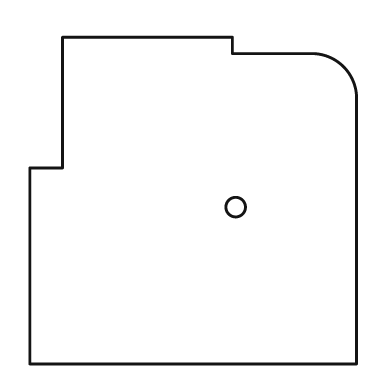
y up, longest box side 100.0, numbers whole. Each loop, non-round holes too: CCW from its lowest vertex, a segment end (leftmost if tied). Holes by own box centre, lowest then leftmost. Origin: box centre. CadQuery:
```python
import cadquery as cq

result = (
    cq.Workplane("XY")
    .moveTo(-50.0, -50.0)
    .lineTo(50.0, -50.0)
    .lineTo(50.0, 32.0)
    .threePointArc((46.0, 41.0), (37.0, 45.0))
    .lineTo(12.0, 45.0)
    .lineTo(12.0, 50.0)
    .lineTo(-40.0, 50.0)
    .lineTo(-40.0, 10.0)
    .lineTo(-50.0, 10.0)
    .close()
    .moveTo(13.0, -2.0)
    .circle(3.0)
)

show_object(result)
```